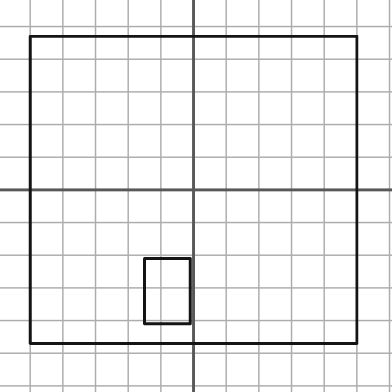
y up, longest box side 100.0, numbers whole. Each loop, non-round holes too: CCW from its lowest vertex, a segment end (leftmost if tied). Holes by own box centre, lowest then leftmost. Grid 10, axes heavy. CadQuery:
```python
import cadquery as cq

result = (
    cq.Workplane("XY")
    .moveTo(-50.0, -47.0)
    .lineTo(50.0, -47.0)
    .lineTo(50.0, 47.0)
    .lineTo(-50.0, 47.0)
    .close()
    .moveTo(-15.0, -41.0)
    .lineTo(-1.0, -41.0)
    .lineTo(-1.0, -21.0)
    .lineTo(-15.0, -21.0)
    .close()
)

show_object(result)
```